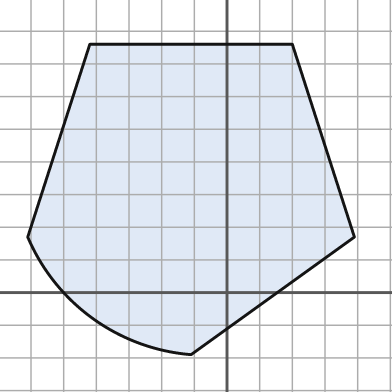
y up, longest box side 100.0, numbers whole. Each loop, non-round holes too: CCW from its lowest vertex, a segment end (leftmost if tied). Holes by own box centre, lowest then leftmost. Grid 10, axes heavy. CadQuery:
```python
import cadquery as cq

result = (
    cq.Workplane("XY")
    .moveTo(-11.0, -19.0)
    .lineTo(39.0, 17.0)
    .lineTo(20.0, 76.0)
    .lineTo(-42.0, 76.0)
    .lineTo(-61.0, 17.0)
    .threePointArc((-41.0, -8.0), (-11.0, -19.0))
    .close()
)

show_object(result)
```